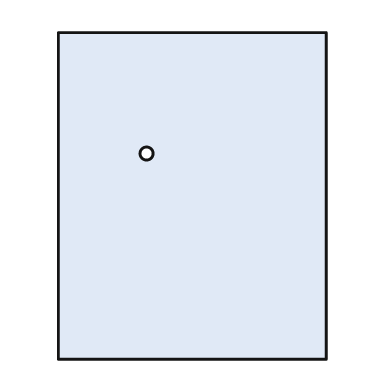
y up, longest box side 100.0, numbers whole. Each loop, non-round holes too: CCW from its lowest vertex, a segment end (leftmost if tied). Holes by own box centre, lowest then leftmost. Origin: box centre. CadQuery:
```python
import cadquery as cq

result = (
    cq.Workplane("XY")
    .moveTo(-41.0, -50.0)
    .lineTo(41.0, -50.0)
    .lineTo(41.0, 50.0)
    .lineTo(-41.0, 50.0)
    .close()
    .moveTo(-14.0, 13.0)
    .circle(2.0)
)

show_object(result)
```